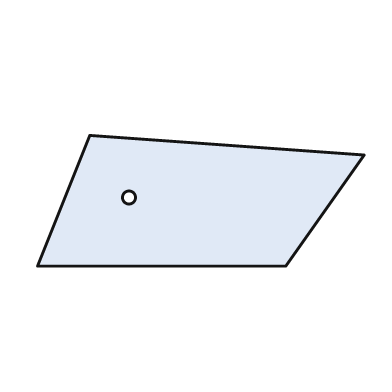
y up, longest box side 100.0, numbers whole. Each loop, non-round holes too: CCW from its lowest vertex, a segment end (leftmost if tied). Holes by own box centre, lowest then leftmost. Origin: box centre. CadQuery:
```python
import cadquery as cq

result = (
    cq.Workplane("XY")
    .moveTo(-50.0, -20.0)
    .lineTo(26.0, -20.0)
    .lineTo(50.0, 14.0)
    .lineTo(-34.0, 20.0)
    .close()
    .moveTo(-22.0, 1.0)
    .circle(2.0)
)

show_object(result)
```